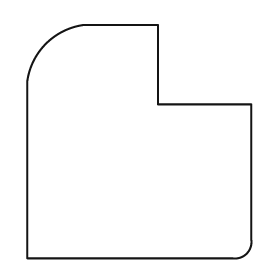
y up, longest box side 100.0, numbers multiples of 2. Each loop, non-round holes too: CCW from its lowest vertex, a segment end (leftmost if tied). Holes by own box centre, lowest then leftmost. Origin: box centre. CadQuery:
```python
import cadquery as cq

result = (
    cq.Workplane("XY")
    .moveTo(-48.0, -50.0)
    .lineTo(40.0, -50.0)
    .threePointArc((46.0, -48.0), (48.0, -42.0))
    .lineTo(48.0, 16.0)
    .lineTo(8.0, 16.0)
    .lineTo(8.0, 50.0)
    .lineTo(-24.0, 50.0)
    .threePointArc((-40.0, 42.0), (-48.0, 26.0))
    .close()
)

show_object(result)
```